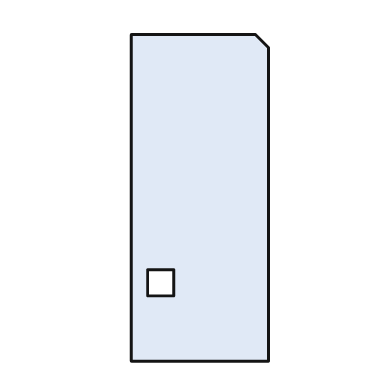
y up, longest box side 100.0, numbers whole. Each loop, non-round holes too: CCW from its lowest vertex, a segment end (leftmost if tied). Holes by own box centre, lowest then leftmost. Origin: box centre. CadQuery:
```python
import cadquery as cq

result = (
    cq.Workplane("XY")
    .moveTo(-21.0, -50.0)
    .lineTo(21.0, -50.0)
    .lineTo(21.0, 46.0)
    .lineTo(17.0, 50.0)
    .lineTo(-21.0, 50.0)
    .close()
    .moveTo(-16.0, -30.0)
    .lineTo(-8.0, -30.0)
    .lineTo(-8.0, -22.0)
    .lineTo(-16.0, -22.0)
    .close()
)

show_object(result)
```